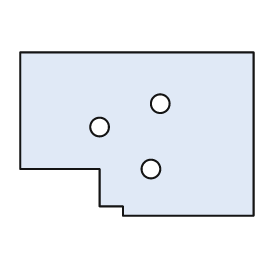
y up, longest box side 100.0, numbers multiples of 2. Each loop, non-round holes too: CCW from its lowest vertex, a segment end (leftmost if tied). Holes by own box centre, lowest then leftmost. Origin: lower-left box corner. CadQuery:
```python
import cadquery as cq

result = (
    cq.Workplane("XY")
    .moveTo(44.0, 0.0)
    .lineTo(100.0, 0.0)
    .lineTo(100.0, 70.0)
    .lineTo(0.0, 70.0)
    .lineTo(0.0, 20.0)
    .lineTo(34.0, 20.0)
    .lineTo(34.0, 4.0)
    .lineTo(44.0, 4.0)
    .close()
    .moveTo(56.0, 20.0)
    .circle(4.0)
    .moveTo(34.0, 38.0)
    .circle(4.0)
    .moveTo(60.0, 48.0)
    .circle(4.0)
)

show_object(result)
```